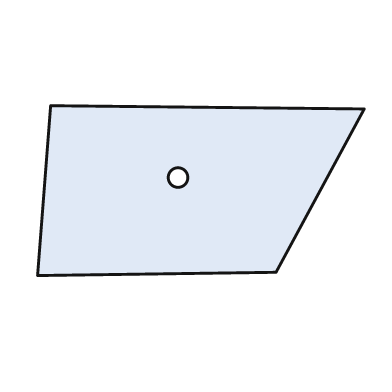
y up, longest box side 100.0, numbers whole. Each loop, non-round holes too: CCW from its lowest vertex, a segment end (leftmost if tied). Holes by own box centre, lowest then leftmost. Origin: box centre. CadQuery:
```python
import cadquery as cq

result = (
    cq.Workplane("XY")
    .moveTo(-50.0, -26.0)
    .lineTo(23.0, -25.0)
    .lineTo(50.0, 25.0)
    .lineTo(-46.0, 26.0)
    .close()
    .moveTo(-7.0, 4.0)
    .circle(3.0)
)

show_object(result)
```